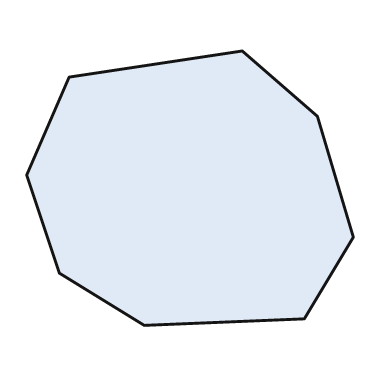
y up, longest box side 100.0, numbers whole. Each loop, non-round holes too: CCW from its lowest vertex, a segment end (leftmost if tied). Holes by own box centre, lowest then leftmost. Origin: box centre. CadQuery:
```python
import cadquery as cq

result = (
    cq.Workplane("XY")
    .moveTo(-14.0, -42.0)
    .lineTo(35.0, -40.0)
    .lineTo(50.0, -15.0)
    .lineTo(39.0, 22.0)
    .lineTo(16.0, 42.0)
    .lineTo(-37.0, 34.0)
    .lineTo(-50.0, 4.0)
    .lineTo(-40.0, -26.0)
    .close()
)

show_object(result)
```